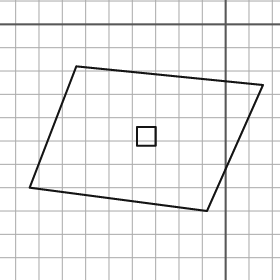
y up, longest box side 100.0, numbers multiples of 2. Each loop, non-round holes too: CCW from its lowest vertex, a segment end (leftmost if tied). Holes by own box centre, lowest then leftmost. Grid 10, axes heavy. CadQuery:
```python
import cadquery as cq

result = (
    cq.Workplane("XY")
    .moveTo(-8.0, -80.0)
    .lineTo(16.0, -26.0)
    .lineTo(-64.0, -18.0)
    .lineTo(-84.0, -70.0)
    .close()
    .moveTo(-38.0, -52.0)
    .lineTo(-30.0, -52.0)
    .lineTo(-30.0, -44.0)
    .lineTo(-38.0, -44.0)
    .close()
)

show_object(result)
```